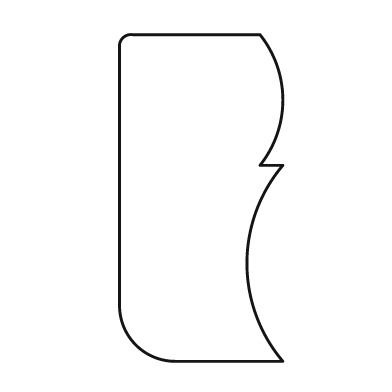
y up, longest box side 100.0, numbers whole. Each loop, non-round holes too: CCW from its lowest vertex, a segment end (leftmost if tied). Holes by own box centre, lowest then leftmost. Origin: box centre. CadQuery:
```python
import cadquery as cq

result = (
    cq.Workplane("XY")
    .moveTo(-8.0, -50.0)
    .lineTo(25.0, -50.0)
    .threePointArc((14.0, -20.0), (25.0, 10.0))
    .lineTo(18.0, 10.0)
    .threePointArc((25.0, 30.0), (18.0, 50.0))
    .lineTo(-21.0, 50.0)
    .threePointArc((-24.0, 49.0), (-25.0, 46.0))
    .lineTo(-25.0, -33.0)
    .threePointArc((-20.0, -45.0), (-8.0, -50.0))
    .close()
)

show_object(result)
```